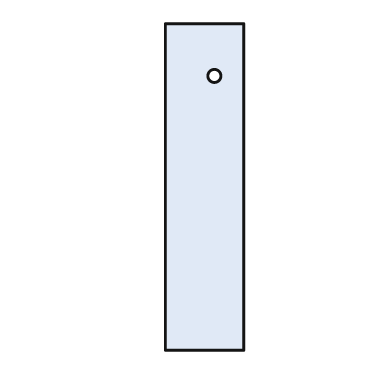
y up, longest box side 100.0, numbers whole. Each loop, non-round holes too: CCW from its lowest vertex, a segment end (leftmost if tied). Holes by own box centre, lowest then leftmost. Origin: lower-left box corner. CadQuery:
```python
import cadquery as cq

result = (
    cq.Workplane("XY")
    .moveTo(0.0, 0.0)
    .lineTo(24.0, 0.0)
    .lineTo(24.0, 100.0)
    .lineTo(0.0, 100.0)
    .close()
    .moveTo(15.0, 84.0)
    .circle(2.0)
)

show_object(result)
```